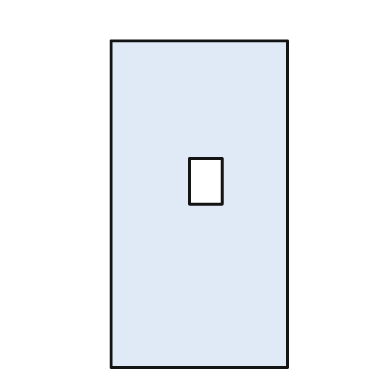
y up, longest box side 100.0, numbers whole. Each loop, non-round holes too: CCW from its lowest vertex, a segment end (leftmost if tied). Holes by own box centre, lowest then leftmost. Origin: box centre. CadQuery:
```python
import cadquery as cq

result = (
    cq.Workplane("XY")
    .moveTo(-27.0, -50.0)
    .lineTo(27.0, -50.0)
    .lineTo(27.0, 50.0)
    .lineTo(-27.0, 50.0)
    .close()
    .moveTo(-3.0, 0.0)
    .lineTo(7.0, 0.0)
    .lineTo(7.0, 14.0)
    .lineTo(-3.0, 14.0)
    .close()
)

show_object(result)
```